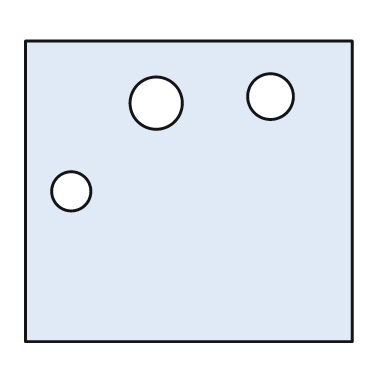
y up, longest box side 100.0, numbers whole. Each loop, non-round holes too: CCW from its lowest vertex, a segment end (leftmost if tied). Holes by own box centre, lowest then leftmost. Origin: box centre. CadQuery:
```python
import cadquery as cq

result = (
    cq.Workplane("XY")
    .moveTo(-50.0, -46.0)
    .lineTo(50.0, -46.0)
    .lineTo(50.0, 46.0)
    .lineTo(-50.0, 46.0)
    .close()
    .moveTo(-36.0, 0.0)
    .circle(6.0)
    .moveTo(-10.0, 27.0)
    .circle(8.0)
    .moveTo(25.0, 29.0)
    .circle(7.0)
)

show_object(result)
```